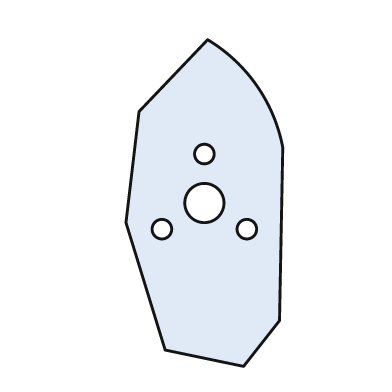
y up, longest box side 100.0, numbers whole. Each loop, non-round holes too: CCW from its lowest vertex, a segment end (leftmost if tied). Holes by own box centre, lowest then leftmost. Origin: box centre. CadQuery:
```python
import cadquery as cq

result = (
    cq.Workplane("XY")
    .moveTo(12.0, -50.0)
    .lineTo(23.0, -36.0)
    .lineTo(24.0, 17.0)
    .threePointArc((16.0, 36.0), (1.0, 50.0))
    .lineTo(-20.0, 28.0)
    .lineTo(-24.0, -6.0)
    .lineTo(-12.0, -45.0)
    .close()
    .moveTo(-13.0, -8.0)
    .circle(3.0)
    .moveTo(13.0, -8.0)
    .circle(3.0)
    .moveTo(0.0, 0.0)
    .circle(6.0)
    .moveTo(0.0, 15.0)
    .circle(3.0)
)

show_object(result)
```